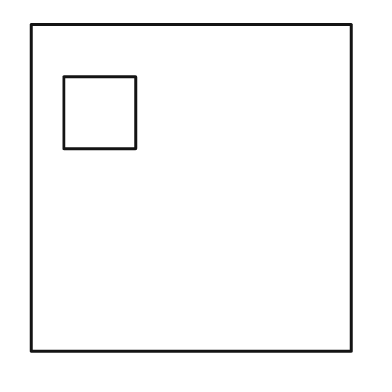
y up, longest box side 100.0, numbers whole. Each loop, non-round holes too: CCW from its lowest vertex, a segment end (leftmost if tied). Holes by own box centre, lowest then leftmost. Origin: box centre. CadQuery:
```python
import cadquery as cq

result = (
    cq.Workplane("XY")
    .moveTo(-49.0, -50.0)
    .lineTo(49.0, -50.0)
    .lineTo(49.0, 50.0)
    .lineTo(-49.0, 50.0)
    .close()
    .moveTo(-39.0, 12.0)
    .lineTo(-17.0, 12.0)
    .lineTo(-17.0, 34.0)
    .lineTo(-39.0, 34.0)
    .close()
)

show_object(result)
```